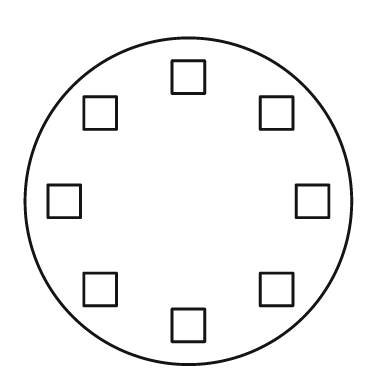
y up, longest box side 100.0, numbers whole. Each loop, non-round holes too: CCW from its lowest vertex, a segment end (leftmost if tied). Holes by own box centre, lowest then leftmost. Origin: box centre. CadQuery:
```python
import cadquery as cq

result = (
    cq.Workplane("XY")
    .moveTo(0.0, 0.0)
    .circle(50.0)
    .moveTo(-5.0, -43.0)
    .lineTo(5.0, -43.0)
    .lineTo(5.0, -33.0)
    .lineTo(-5.0, -33.0)
    .close()
    .moveTo(-32.0, -32.0)
    .lineTo(-22.0, -32.0)
    .lineTo(-22.0, -22.0)
    .lineTo(-32.0, -22.0)
    .close()
    .moveTo(22.0, -32.0)
    .lineTo(32.0, -32.0)
    .lineTo(32.0, -22.0)
    .lineTo(22.0, -22.0)
    .close()
    .moveTo(-43.0, -5.0)
    .lineTo(-33.0, -5.0)
    .lineTo(-33.0, 5.0)
    .lineTo(-43.0, 5.0)
    .close()
    .moveTo(33.0, -5.0)
    .lineTo(43.0, -5.0)
    .lineTo(43.0, 5.0)
    .lineTo(33.0, 5.0)
    .close()
    .moveTo(-32.0, 22.0)
    .lineTo(-22.0, 22.0)
    .lineTo(-22.0, 32.0)
    .lineTo(-32.0, 32.0)
    .close()
    .moveTo(22.0, 22.0)
    .lineTo(32.0, 22.0)
    .lineTo(32.0, 32.0)
    .lineTo(22.0, 32.0)
    .close()
    .moveTo(-5.0, 33.0)
    .lineTo(5.0, 33.0)
    .lineTo(5.0, 43.0)
    .lineTo(-5.0, 43.0)
    .close()
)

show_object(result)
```